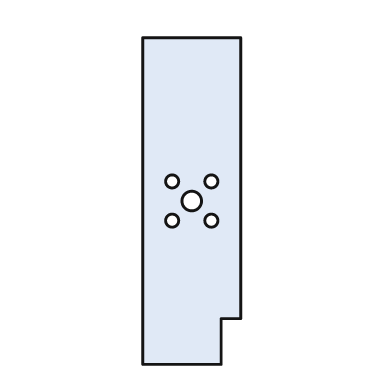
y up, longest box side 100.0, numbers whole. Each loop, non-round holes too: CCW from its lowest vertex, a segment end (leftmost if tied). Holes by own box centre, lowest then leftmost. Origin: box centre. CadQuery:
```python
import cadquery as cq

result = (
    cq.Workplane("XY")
    .moveTo(-15.0, -50.0)
    .lineTo(9.0, -50.0)
    .lineTo(9.0, -36.0)
    .lineTo(15.0, -36.0)
    .lineTo(15.0, 50.0)
    .lineTo(-15.0, 50.0)
    .close()
    .moveTo(-6.0, -6.0)
    .circle(2.0)
    .moveTo(6.0, -6.0)
    .circle(2.0)
    .moveTo(0.0, 0.0)
    .circle(3.0)
    .moveTo(-6.0, 6.0)
    .circle(2.0)
    .moveTo(6.0, 6.0)
    .circle(2.0)
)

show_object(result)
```